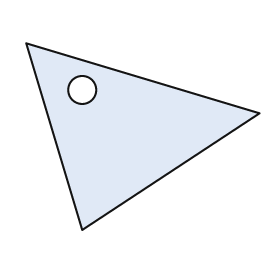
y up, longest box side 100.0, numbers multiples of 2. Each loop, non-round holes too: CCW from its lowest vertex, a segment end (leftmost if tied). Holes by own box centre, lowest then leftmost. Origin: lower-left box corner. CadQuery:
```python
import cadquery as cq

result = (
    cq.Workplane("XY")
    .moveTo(24.0, 0.0)
    .lineTo(100.0, 50.0)
    .lineTo(0.0, 80.0)
    .close()
    .moveTo(24.0, 60.0)
    .circle(6.0)
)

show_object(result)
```